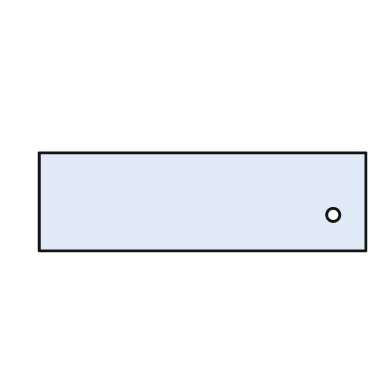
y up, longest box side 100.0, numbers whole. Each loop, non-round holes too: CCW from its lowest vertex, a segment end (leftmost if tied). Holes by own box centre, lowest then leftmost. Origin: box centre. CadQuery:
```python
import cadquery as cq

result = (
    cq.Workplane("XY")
    .moveTo(-50.0, -15.0)
    .lineTo(50.0, -15.0)
    .lineTo(50.0, 15.0)
    .lineTo(-50.0, 15.0)
    .close()
    .moveTo(40.0, -4.0)
    .circle(2.0)
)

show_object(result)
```